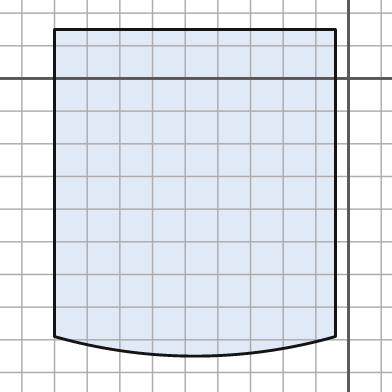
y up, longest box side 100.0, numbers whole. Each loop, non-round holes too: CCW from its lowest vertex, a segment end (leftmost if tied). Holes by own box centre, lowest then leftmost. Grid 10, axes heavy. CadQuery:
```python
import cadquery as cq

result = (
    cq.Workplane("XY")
    .moveTo(-90.0, -79.0)
    .threePointArc((-47.0, -85.0), (-4.0, -79.0))
    .lineTo(-4.0, 15.0)
    .lineTo(-90.0, 15.0)
    .close()
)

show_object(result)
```